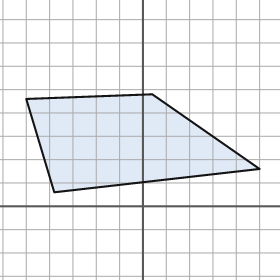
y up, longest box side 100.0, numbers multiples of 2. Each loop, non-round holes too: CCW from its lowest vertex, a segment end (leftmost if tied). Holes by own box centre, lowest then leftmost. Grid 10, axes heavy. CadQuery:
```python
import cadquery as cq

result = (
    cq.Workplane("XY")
    .moveTo(-38.0, 6.0)
    .lineTo(50.0, 16.0)
    .lineTo(4.0, 48.0)
    .lineTo(-50.0, 46.0)
    .close()
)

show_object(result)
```